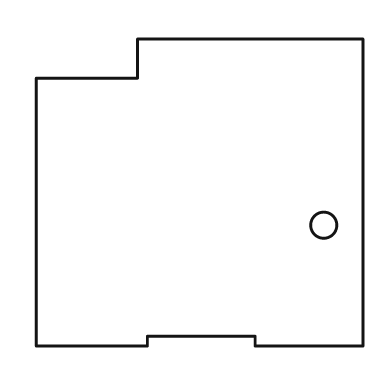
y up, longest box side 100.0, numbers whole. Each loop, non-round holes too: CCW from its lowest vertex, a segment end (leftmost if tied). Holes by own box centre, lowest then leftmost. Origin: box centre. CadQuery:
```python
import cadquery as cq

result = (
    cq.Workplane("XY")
    .moveTo(-50.0, -47.0)
    .lineTo(-16.0, -47.0)
    .lineTo(-16.0, -44.0)
    .lineTo(17.0, -44.0)
    .lineTo(17.0, -47.0)
    .lineTo(50.0, -47.0)
    .lineTo(50.0, 47.0)
    .lineTo(-19.0, 47.0)
    .lineTo(-19.0, 35.0)
    .lineTo(-50.0, 35.0)
    .close()
    .moveTo(38.0, -10.0)
    .circle(4.0)
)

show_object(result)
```